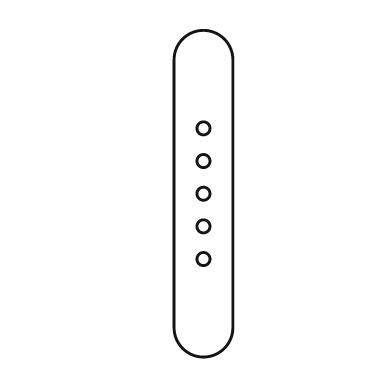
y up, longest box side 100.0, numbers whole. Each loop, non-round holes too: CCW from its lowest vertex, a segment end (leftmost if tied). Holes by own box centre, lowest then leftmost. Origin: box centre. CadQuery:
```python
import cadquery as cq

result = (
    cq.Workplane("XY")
    .moveTo(-9.0, -41.0)
    .threePointArc((0.0, -50.0), (9.0, -41.0))
    .lineTo(9.0, 41.0)
    .threePointArc((0.0, 50.0), (-9.0, 41.0))
    .close()
    .moveTo(0.0, -20.0)
    .circle(2.0)
    .moveTo(0.0, -10.0)
    .circle(2.0)
    .moveTo(0.0, 0.0)
    .circle(2.0)
    .moveTo(0.0, 10.0)
    .circle(2.0)
    .moveTo(0.0, 20.0)
    .circle(2.0)
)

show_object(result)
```